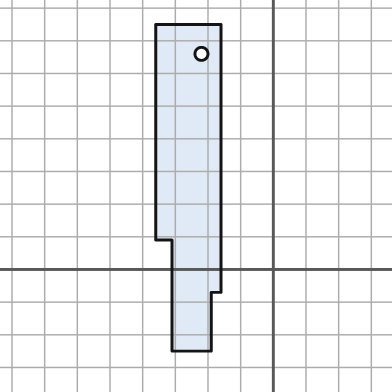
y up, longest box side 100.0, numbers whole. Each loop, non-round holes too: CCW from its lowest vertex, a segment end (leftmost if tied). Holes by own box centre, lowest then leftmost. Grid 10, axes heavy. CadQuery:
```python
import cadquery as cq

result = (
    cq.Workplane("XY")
    .moveTo(-31.0, -25.0)
    .lineTo(-19.0, -25.0)
    .lineTo(-19.0, -7.0)
    .lineTo(-16.0, -7.0)
    .lineTo(-16.0, 75.0)
    .lineTo(-36.0, 75.0)
    .lineTo(-36.0, 9.0)
    .lineTo(-31.0, 9.0)
    .close()
    .moveTo(-22.0, 66.0)
    .circle(2.0)
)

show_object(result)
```